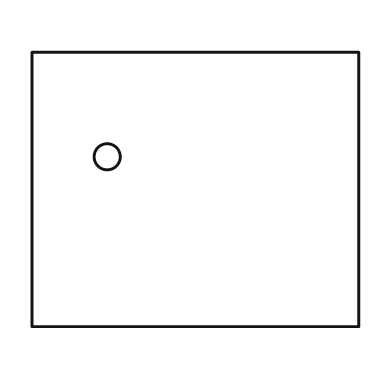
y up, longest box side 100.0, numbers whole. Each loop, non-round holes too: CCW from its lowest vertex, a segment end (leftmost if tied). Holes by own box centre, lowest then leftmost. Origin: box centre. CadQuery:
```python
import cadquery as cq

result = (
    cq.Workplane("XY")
    .moveTo(-50.0, -42.0)
    .lineTo(50.0, -42.0)
    .lineTo(50.0, 42.0)
    .lineTo(-50.0, 42.0)
    .close()
    .moveTo(-27.0, 10.0)
    .circle(4.0)
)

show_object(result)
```